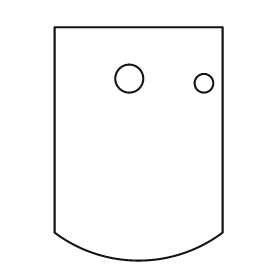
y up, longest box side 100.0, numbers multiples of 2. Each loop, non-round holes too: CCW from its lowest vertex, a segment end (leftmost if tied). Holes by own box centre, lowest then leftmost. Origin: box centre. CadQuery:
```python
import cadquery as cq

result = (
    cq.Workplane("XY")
    .moveTo(-36.0, -38.0)
    .threePointArc((0.0, -50.0), (36.0, -38.0))
    .lineTo(36.0, 50.0)
    .lineTo(-36.0, 50.0)
    .close()
    .moveTo(28.0, 26.0)
    .circle(4.0)
    .moveTo(-4.0, 28.0)
    .circle(6.0)
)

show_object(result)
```